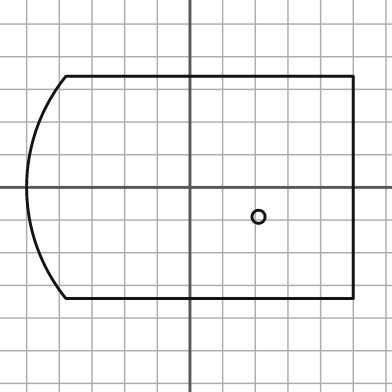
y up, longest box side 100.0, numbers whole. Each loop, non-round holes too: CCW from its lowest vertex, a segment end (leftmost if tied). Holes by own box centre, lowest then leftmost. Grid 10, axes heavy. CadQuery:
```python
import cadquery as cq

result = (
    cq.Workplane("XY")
    .moveTo(-38.0, -34.0)
    .lineTo(50.0, -34.0)
    .lineTo(50.0, 34.0)
    .lineTo(-38.0, 34.0)
    .threePointArc((-50.0, 0.0), (-38.0, -34.0))
    .close()
    .moveTo(21.0, -9.0)
    .circle(2.0)
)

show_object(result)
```